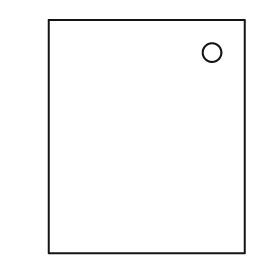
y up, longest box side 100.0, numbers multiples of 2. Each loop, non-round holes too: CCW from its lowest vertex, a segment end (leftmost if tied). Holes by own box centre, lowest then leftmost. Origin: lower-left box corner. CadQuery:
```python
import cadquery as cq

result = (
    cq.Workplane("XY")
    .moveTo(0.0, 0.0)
    .lineTo(84.0, 0.0)
    .lineTo(84.0, 100.0)
    .lineTo(0.0, 100.0)
    .close()
    .moveTo(70.0, 86.0)
    .circle(4.0)
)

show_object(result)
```